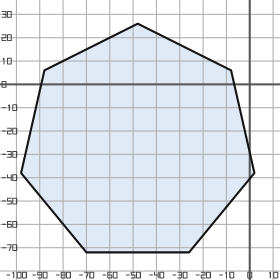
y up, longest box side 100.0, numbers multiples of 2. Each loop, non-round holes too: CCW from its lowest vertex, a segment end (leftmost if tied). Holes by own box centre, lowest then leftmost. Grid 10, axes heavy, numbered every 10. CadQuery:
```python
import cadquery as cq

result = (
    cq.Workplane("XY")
    .moveTo(-70.0, -72.0)
    .lineTo(-26.0, -72.0)
    .lineTo(2.0, -38.0)
    .lineTo(-8.0, 6.0)
    .lineTo(-48.0, 26.0)
    .lineTo(-88.0, 6.0)
    .lineTo(-98.0, -38.0)
    .close()
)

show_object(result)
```